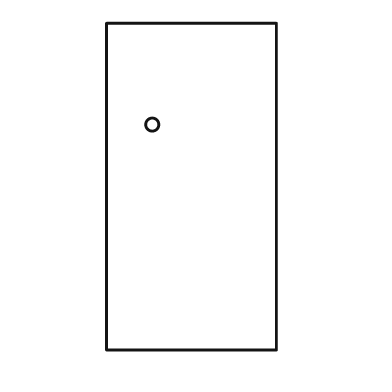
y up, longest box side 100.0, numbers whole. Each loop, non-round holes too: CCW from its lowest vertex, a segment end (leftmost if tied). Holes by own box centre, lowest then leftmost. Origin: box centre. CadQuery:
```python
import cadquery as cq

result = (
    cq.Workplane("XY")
    .moveTo(-26.0, -50.0)
    .lineTo(26.0, -50.0)
    .lineTo(26.0, 50.0)
    .lineTo(-26.0, 50.0)
    .close()
    .moveTo(-12.0, 19.0)
    .circle(2.0)
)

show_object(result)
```